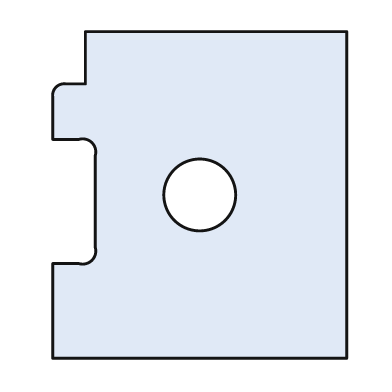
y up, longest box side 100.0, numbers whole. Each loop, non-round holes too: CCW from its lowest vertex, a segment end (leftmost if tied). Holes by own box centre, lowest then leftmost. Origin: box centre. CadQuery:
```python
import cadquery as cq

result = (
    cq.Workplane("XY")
    .moveTo(-45.0, -50.0)
    .lineTo(45.0, -50.0)
    .lineTo(45.0, 50.0)
    .lineTo(-35.0, 50.0)
    .lineTo(-35.0, 34.0)
    .lineTo(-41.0, 34.0)
    .threePointArc((-44.0, 33.0), (-45.0, 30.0))
    .lineTo(-45.0, 17.0)
    .lineTo(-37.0, 17.0)
    .threePointArc((-33.0, 16.0), (-32.0, 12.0))
    .lineTo(-32.0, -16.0)
    .threePointArc((-33.0, -20.0), (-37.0, -21.0))
    .lineTo(-45.0, -21.0)
    .close()
    .moveTo(0.0, 0.0)
    .circle(11.0)
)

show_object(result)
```